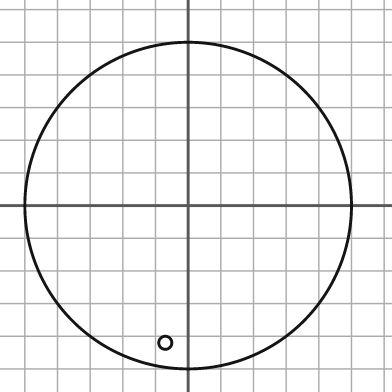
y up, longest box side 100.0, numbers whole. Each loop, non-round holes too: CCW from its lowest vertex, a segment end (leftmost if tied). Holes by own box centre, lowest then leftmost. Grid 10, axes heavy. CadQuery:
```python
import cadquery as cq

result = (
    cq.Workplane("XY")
    .moveTo(0.0, 0.0)
    .circle(50.0)
    .moveTo(-7.0, -42.0)
    .circle(2.0)
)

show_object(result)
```